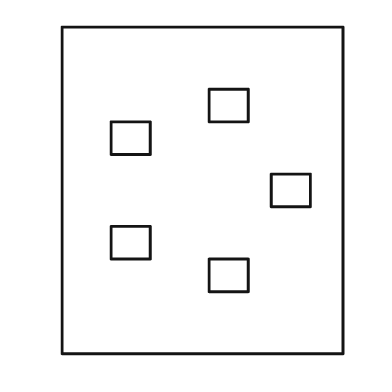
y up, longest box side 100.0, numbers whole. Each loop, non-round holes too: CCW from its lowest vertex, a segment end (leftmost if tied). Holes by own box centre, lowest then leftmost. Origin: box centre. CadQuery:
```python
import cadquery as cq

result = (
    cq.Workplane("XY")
    .moveTo(-43.0, -50.0)
    .lineTo(43.0, -50.0)
    .lineTo(43.0, 50.0)
    .lineTo(-43.0, 50.0)
    .close()
    .moveTo(2.0, -31.0)
    .lineTo(14.0, -31.0)
    .lineTo(14.0, -21.0)
    .lineTo(2.0, -21.0)
    .close()
    .moveTo(-28.0, -21.0)
    .lineTo(-16.0, -21.0)
    .lineTo(-16.0, -11.0)
    .lineTo(-28.0, -11.0)
    .close()
    .moveTo(21.0, -5.0)
    .lineTo(33.0, -5.0)
    .lineTo(33.0, 5.0)
    .lineTo(21.0, 5.0)
    .close()
    .moveTo(-28.0, 11.0)
    .lineTo(-16.0, 11.0)
    .lineTo(-16.0, 21.0)
    .lineTo(-28.0, 21.0)
    .close()
    .moveTo(2.0, 21.0)
    .lineTo(14.0, 21.0)
    .lineTo(14.0, 31.0)
    .lineTo(2.0, 31.0)
    .close()
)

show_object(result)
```